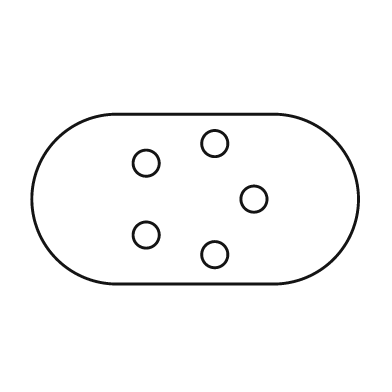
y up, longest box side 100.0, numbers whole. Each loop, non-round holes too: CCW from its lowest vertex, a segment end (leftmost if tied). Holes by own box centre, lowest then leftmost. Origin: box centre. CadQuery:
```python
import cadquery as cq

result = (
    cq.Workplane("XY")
    .moveTo(-24.0, -26.0)
    .lineTo(24.0, -26.0)
    .threePointArc((50.0, 0.0), (24.0, 26.0))
    .lineTo(-24.0, 26.0)
    .threePointArc((-50.0, 0.0), (-24.0, -26.0))
    .close()
    .moveTo(6.0, -17.0)
    .circle(4.0)
    .moveTo(-15.0, -11.0)
    .circle(4.0)
    .moveTo(18.0, 0.0)
    .circle(4.0)
    .moveTo(-15.0, 11.0)
    .circle(4.0)
    .moveTo(6.0, 17.0)
    .circle(4.0)
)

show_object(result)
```